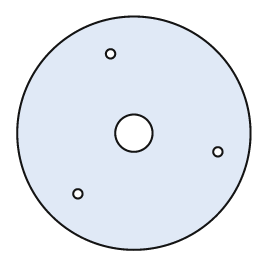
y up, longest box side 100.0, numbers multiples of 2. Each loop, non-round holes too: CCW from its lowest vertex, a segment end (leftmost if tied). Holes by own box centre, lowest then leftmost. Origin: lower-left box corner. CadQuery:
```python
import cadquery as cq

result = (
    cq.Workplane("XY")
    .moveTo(50.0, 50.0)
    .circle(50.0)
    .moveTo(26.0, 24.0)
    .circle(2.0)
    .moveTo(86.0, 42.0)
    .circle(2.0)
    .moveTo(50.0, 50.0)
    .circle(8.0)
    .moveTo(40.0, 84.0)
    .circle(2.0)
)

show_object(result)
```